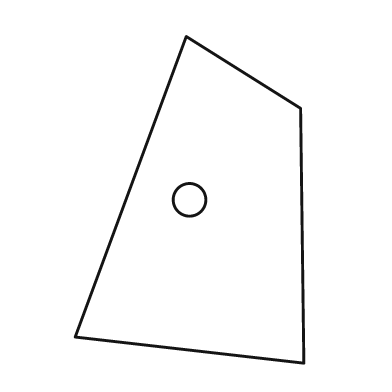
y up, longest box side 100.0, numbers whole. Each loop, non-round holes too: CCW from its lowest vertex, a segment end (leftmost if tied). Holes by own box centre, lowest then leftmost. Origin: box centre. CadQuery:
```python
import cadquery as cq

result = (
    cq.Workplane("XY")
    .moveTo(35.0, -50.0)
    .lineTo(34.0, 28.0)
    .lineTo(-1.0, 50.0)
    .lineTo(-35.0, -42.0)
    .close()
    .moveTo(0.0, 0.0)
    .circle(5.0)
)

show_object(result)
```